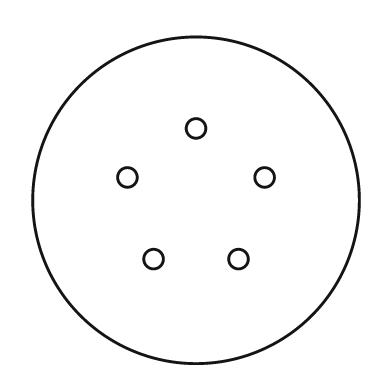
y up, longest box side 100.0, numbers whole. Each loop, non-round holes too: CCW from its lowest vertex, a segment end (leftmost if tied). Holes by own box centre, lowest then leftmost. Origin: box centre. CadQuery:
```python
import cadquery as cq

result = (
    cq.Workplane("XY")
    .moveTo(0.0, 0.0)
    .circle(50.0)
    .moveTo(-13.0, -18.0)
    .circle(3.0)
    .moveTo(13.0, -18.0)
    .circle(3.0)
    .moveTo(-21.0, 7.0)
    .circle(3.0)
    .moveTo(21.0, 7.0)
    .circle(3.0)
    .moveTo(0.0, 22.0)
    .circle(3.0)
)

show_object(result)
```